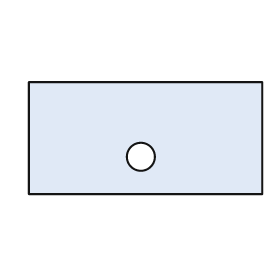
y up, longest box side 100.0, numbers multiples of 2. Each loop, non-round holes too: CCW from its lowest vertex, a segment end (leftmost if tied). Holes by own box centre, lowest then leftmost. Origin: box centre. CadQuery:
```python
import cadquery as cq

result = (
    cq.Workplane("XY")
    .moveTo(-50.0, -24.0)
    .lineTo(50.0, -24.0)
    .lineTo(50.0, 24.0)
    .lineTo(-50.0, 24.0)
    .close()
    .moveTo(-2.0, -8.0)
    .circle(6.0)
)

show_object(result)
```